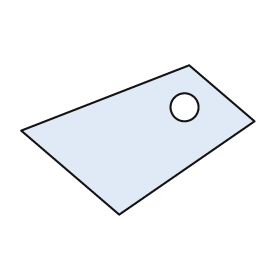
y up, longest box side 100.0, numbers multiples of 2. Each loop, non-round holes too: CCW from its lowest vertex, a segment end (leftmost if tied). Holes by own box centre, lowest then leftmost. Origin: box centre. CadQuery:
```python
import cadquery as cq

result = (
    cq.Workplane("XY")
    .moveTo(-8.0, -32.0)
    .lineTo(50.0, 8.0)
    .lineTo(22.0, 32.0)
    .lineTo(-50.0, 4.0)
    .close()
    .moveTo(20.0, 14.0)
    .circle(6.0)
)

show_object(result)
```